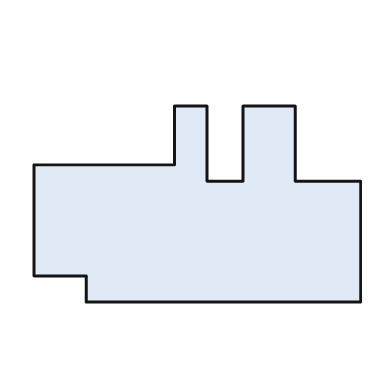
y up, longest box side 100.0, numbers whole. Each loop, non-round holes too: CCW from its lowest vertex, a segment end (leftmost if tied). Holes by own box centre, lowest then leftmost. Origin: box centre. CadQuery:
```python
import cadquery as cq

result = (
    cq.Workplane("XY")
    .moveTo(-34.0, -30.0)
    .lineTo(50.0, -30.0)
    .lineTo(50.0, 7.0)
    .lineTo(30.0, 7.0)
    .lineTo(30.0, 30.0)
    .lineTo(14.0, 30.0)
    .lineTo(14.0, 7.0)
    .lineTo(3.0, 7.0)
    .lineTo(3.0, 30.0)
    .lineTo(-7.0, 30.0)
    .lineTo(-7.0, 12.0)
    .lineTo(-50.0, 12.0)
    .lineTo(-50.0, -22.0)
    .lineTo(-34.0, -22.0)
    .close()
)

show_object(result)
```